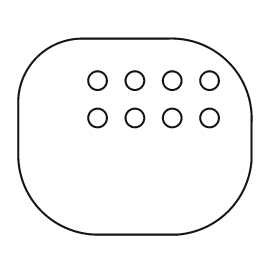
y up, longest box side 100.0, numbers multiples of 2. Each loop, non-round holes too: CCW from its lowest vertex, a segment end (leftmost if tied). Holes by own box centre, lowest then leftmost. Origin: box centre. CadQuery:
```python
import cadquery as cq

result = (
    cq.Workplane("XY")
    .moveTo(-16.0, -42.0)
    .lineTo(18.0, -42.0)
    .threePointArc((40.0, -32.0), (50.0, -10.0))
    .lineTo(50.0, 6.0)
    .threePointArc((40.0, 32.0), (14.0, 42.0))
    .lineTo(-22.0, 42.0)
    .threePointArc((-42.0, 34.0), (-50.0, 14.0))
    .lineTo(-50.0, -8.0)
    .threePointArc((-40.0, -32.0), (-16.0, -42.0))
    .close()
    .moveTo(-16.0, 8.0)
    .circle(4.0)
    .moveTo(0.0, 8.0)
    .circle(4.0)
    .moveTo(16.0, 8.0)
    .circle(4.0)
    .moveTo(32.0, 8.0)
    .circle(4.0)
    .moveTo(-16.0, 24.0)
    .circle(4.0)
    .moveTo(0.0, 24.0)
    .circle(4.0)
    .moveTo(16.0, 24.0)
    .circle(4.0)
    .moveTo(32.0, 24.0)
    .circle(4.0)
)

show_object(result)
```